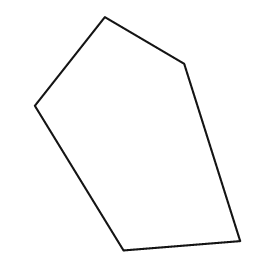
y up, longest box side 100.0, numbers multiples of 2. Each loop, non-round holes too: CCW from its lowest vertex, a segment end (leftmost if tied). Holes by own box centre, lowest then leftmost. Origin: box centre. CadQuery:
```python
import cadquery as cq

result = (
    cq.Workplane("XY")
    .moveTo(-6.0, -50.0)
    .lineTo(44.0, -46.0)
    .lineTo(20.0, 30.0)
    .lineTo(-14.0, 50.0)
    .lineTo(-44.0, 12.0)
    .close()
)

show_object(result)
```